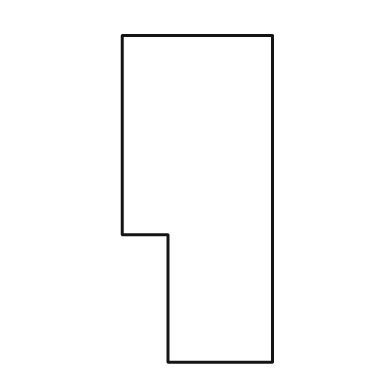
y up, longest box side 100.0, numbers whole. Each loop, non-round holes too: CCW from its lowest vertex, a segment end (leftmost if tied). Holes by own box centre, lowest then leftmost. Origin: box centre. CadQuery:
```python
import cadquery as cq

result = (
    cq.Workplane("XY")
    .moveTo(-9.0, -50.0)
    .lineTo(23.0, -50.0)
    .lineTo(23.0, 50.0)
    .lineTo(-23.0, 50.0)
    .lineTo(-23.0, -11.0)
    .lineTo(-9.0, -11.0)
    .close()
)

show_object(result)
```